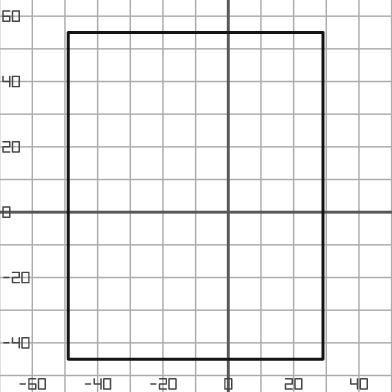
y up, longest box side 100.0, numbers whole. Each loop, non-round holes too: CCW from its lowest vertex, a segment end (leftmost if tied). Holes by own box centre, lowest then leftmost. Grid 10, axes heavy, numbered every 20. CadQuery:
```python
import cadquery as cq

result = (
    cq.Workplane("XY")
    .moveTo(-49.0, -45.0)
    .lineTo(29.0, -45.0)
    .lineTo(29.0, 55.0)
    .lineTo(-49.0, 55.0)
    .close()
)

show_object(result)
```